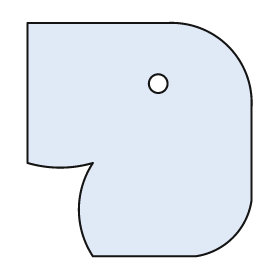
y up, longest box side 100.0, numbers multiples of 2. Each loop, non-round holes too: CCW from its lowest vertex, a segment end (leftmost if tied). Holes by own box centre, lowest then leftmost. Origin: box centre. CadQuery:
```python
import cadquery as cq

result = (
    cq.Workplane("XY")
    .moveTo(-20.0, -50.0)
    .lineTo(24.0, -50.0)
    .threePointArc((40.0, -42.0), (48.0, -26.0))
    .lineTo(48.0, 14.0)
    .threePointArc((38.0, 40.0), (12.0, 50.0))
    .lineTo(-48.0, 50.0)
    .lineTo(-48.0, -10.0)
    .threePointArc((-34.0, -12.0), (-20.0, -10.0))
    .threePointArc((-26.0, -30.0), (-20.0, -50.0))
    .close()
    .moveTo(8.0, 24.0)
    .circle(4.0)
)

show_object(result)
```